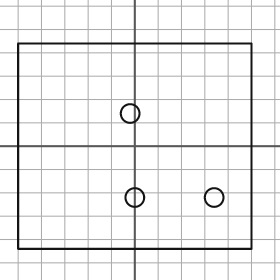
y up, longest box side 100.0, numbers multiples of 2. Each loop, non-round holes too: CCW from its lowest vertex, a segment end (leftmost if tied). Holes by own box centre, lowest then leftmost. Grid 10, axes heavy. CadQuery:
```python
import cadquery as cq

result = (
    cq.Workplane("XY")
    .moveTo(-50.0, -44.0)
    .lineTo(50.0, -44.0)
    .lineTo(50.0, 44.0)
    .lineTo(-50.0, 44.0)
    .close()
    .moveTo(0.0, -22.0)
    .circle(4.0)
    .moveTo(34.0, -22.0)
    .circle(4.0)
    .moveTo(-2.0, 14.0)
    .circle(4.0)
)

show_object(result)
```